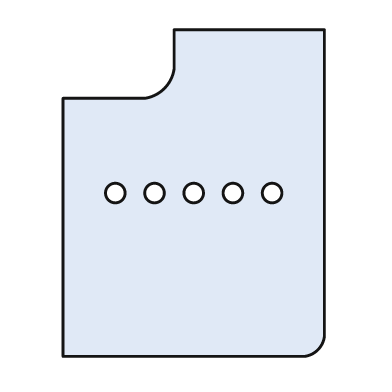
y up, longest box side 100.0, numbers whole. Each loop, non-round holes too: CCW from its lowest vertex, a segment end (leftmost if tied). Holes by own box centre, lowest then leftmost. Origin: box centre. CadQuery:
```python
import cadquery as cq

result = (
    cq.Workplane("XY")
    .moveTo(-40.0, -50.0)
    .lineTo(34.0, -50.0)
    .threePointArc((38.0, -48.0), (40.0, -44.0))
    .lineTo(40.0, 50.0)
    .lineTo(-6.0, 50.0)
    .lineTo(-6.0, 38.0)
    .threePointArc((-9.0, 32.0), (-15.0, 29.0))
    .lineTo(-40.0, 29.0)
    .close()
    .moveTo(-24.0, 0.0)
    .circle(3.0)
    .moveTo(-12.0, 0.0)
    .circle(3.0)
    .moveTo(0.0, 0.0)
    .circle(3.0)
    .moveTo(12.0, 0.0)
    .circle(3.0)
    .moveTo(24.0, 0.0)
    .circle(3.0)
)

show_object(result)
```